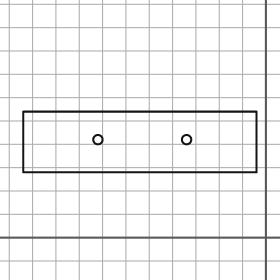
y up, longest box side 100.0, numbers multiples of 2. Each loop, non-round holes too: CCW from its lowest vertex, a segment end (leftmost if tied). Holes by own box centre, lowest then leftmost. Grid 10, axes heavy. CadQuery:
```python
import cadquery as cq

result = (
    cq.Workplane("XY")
    .moveTo(-104.0, 28.0)
    .lineTo(-4.0, 28.0)
    .lineTo(-4.0, 54.0)
    .lineTo(-104.0, 54.0)
    .close()
    .moveTo(-72.0, 42.0)
    .circle(2.0)
    .moveTo(-34.0, 42.0)
    .circle(2.0)
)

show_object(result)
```